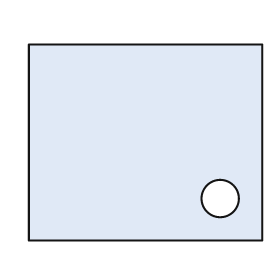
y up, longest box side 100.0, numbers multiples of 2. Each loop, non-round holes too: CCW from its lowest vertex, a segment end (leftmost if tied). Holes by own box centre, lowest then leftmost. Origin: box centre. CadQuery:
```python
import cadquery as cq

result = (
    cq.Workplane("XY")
    .moveTo(-50.0, -42.0)
    .lineTo(50.0, -42.0)
    .lineTo(50.0, 42.0)
    .lineTo(-50.0, 42.0)
    .close()
    .moveTo(32.0, -24.0)
    .circle(8.0)
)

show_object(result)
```